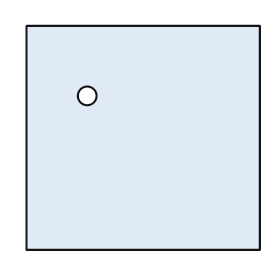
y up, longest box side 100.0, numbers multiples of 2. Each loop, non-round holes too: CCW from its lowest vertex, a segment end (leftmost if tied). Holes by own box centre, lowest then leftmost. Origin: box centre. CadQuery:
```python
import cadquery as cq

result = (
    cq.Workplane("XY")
    .moveTo(-50.0, -48.0)
    .lineTo(50.0, -48.0)
    .lineTo(50.0, 48.0)
    .lineTo(-50.0, 48.0)
    .close()
    .moveTo(-24.0, 18.0)
    .circle(4.0)
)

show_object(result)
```